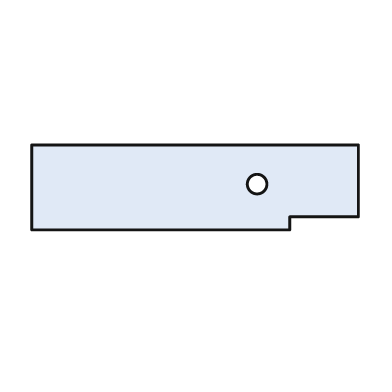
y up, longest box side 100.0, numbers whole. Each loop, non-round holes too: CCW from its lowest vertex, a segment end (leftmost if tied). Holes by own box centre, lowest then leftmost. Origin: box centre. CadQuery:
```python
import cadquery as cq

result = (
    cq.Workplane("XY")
    .moveTo(-50.0, -13.0)
    .lineTo(29.0, -13.0)
    .lineTo(29.0, -9.0)
    .lineTo(50.0, -9.0)
    .lineTo(50.0, 13.0)
    .lineTo(-50.0, 13.0)
    .close()
    .moveTo(19.0, 1.0)
    .circle(3.0)
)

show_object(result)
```